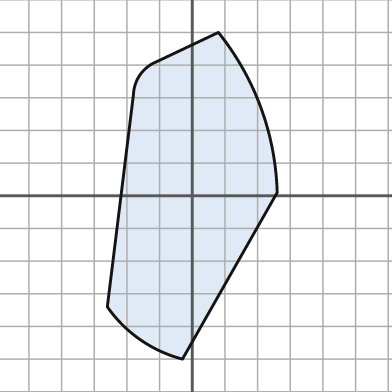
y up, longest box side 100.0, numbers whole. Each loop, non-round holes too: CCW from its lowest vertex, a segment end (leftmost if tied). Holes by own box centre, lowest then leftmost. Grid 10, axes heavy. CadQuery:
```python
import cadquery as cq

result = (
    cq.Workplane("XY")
    .moveTo(-3.0, -50.0)
    .lineTo(26.0, 1.0)
    .threePointArc((21.0, 27.0), (8.0, 50.0))
    .lineTo(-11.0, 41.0)
    .threePointArc((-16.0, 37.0), (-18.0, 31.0))
    .lineTo(-26.0, -34.0)
    .threePointArc((-16.0, -44.0), (-3.0, -50.0))
    .close()
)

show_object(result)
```